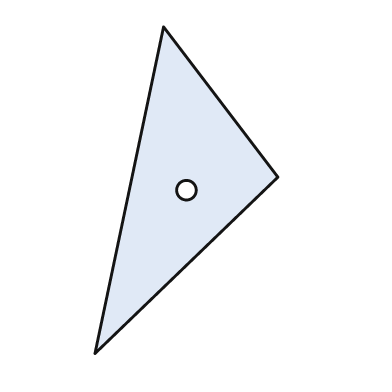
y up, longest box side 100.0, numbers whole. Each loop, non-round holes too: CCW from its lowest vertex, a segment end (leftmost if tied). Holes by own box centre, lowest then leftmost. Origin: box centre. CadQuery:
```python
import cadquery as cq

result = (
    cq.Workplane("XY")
    .moveTo(-28.0, -50.0)
    .lineTo(28.0, 4.0)
    .lineTo(-7.0, 50.0)
    .close()
    .moveTo(0.0, 0.0)
    .circle(3.0)
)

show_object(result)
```